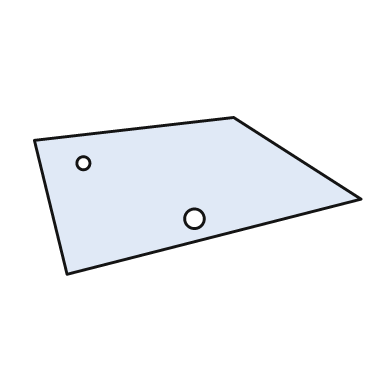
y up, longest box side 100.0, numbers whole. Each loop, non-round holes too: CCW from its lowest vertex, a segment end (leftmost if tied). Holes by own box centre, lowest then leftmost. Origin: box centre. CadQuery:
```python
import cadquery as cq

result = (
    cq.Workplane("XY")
    .moveTo(-40.0, -24.0)
    .lineTo(50.0, -1.0)
    .lineTo(11.0, 24.0)
    .lineTo(-50.0, 17.0)
    .close()
    .moveTo(-1.0, -7.0)
    .circle(3.0)
    .moveTo(-35.0, 10.0)
    .circle(2.0)
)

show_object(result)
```